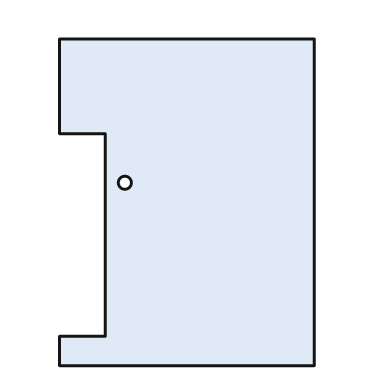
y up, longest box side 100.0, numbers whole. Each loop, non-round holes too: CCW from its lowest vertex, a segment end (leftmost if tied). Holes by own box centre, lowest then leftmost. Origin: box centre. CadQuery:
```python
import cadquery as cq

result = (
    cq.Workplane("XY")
    .moveTo(-39.0, -50.0)
    .lineTo(39.0, -50.0)
    .lineTo(39.0, 50.0)
    .lineTo(-39.0, 50.0)
    .lineTo(-39.0, 21.0)
    .lineTo(-25.0, 21.0)
    .lineTo(-25.0, -41.0)
    .lineTo(-39.0, -41.0)
    .close()
    .moveTo(-19.0, 6.0)
    .circle(2.0)
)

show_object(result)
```